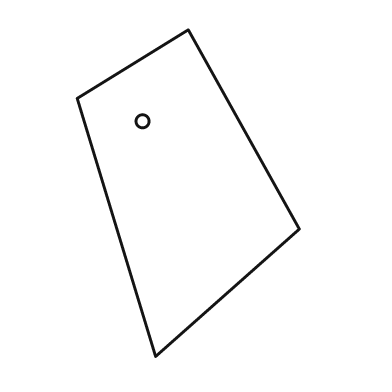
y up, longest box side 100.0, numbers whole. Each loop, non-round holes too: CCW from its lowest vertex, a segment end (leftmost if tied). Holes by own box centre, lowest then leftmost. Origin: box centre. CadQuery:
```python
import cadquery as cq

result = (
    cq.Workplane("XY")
    .moveTo(-10.0, -50.0)
    .lineTo(34.0, -11.0)
    .lineTo(0.0, 50.0)
    .lineTo(-34.0, 29.0)
    .close()
    .moveTo(-14.0, 22.0)
    .circle(2.0)
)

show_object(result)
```